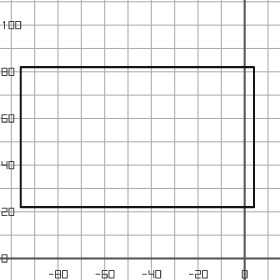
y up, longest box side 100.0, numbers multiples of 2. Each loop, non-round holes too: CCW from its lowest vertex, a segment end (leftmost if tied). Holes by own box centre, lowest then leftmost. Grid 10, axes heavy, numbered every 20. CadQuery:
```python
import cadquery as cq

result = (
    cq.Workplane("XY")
    .moveTo(-96.0, 22.0)
    .lineTo(4.0, 22.0)
    .lineTo(4.0, 82.0)
    .lineTo(-96.0, 82.0)
    .close()
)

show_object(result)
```